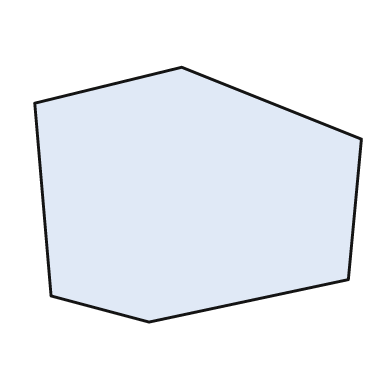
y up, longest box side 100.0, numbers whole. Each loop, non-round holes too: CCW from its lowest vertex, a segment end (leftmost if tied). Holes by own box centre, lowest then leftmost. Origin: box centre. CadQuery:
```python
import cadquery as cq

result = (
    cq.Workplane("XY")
    .moveTo(-15.0, -39.0)
    .lineTo(46.0, -26.0)
    .lineTo(50.0, 17.0)
    .lineTo(-5.0, 39.0)
    .lineTo(-50.0, 28.0)
    .lineTo(-45.0, -31.0)
    .close()
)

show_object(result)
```